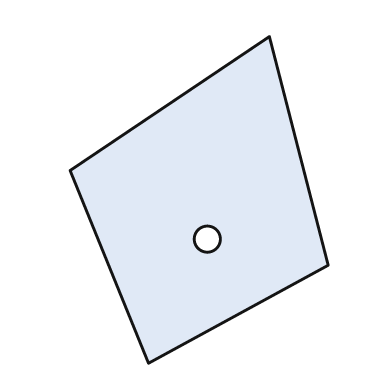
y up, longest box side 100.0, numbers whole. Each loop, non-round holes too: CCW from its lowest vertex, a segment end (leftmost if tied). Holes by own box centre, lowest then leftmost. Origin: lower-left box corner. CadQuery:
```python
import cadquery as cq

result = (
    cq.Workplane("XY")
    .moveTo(24.0, 0.0)
    .lineTo(79.0, 30.0)
    .lineTo(61.0, 100.0)
    .lineTo(0.0, 59.0)
    .close()
    .moveTo(42.0, 38.0)
    .circle(4.0)
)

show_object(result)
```